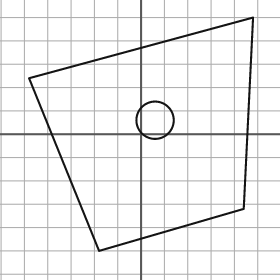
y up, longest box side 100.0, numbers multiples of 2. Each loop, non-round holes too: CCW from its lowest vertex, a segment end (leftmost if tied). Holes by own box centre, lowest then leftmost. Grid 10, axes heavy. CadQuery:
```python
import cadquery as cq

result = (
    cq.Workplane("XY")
    .moveTo(-18.0, -50.0)
    .lineTo(44.0, -32.0)
    .lineTo(48.0, 50.0)
    .lineTo(-48.0, 24.0)
    .close()
    .moveTo(6.0, 6.0)
    .circle(8.0)
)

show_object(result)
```